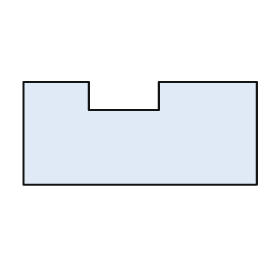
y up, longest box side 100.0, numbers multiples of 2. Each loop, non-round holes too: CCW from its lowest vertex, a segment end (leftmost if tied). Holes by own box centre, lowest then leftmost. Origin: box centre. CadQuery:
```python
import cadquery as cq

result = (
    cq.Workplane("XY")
    .moveTo(-50.0, -22.0)
    .lineTo(50.0, -22.0)
    .lineTo(50.0, 22.0)
    .lineTo(8.0, 22.0)
    .lineTo(8.0, 10.0)
    .lineTo(-22.0, 10.0)
    .lineTo(-22.0, 22.0)
    .lineTo(-50.0, 22.0)
    .close()
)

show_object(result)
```